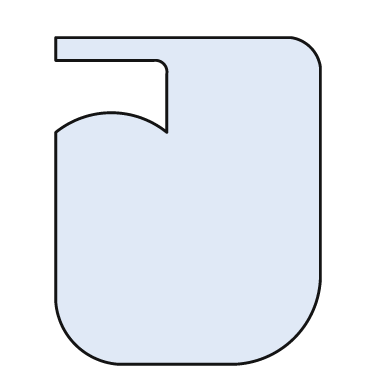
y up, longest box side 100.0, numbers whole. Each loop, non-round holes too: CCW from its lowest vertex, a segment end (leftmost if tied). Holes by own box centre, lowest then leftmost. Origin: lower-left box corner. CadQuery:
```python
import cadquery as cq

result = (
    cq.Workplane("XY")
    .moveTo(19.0, 0.0)
    .lineTo(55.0, 0.0)
    .threePointArc((73.0, 8.0), (81.0, 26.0))
    .lineTo(81.0, 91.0)
    .threePointArc((78.0, 97.0), (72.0, 100.0))
    .lineTo(0.0, 100.0)
    .lineTo(0.0, 93.0)
    .lineTo(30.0, 93.0)
    .threePointArc((33.0, 92.0), (34.0, 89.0))
    .lineTo(34.0, 71.0)
    .threePointArc((17.0, 77.0), (0.0, 71.0))
    .lineTo(0.0, 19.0)
    .threePointArc((6.0, 6.0), (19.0, 0.0))
    .close()
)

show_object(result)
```